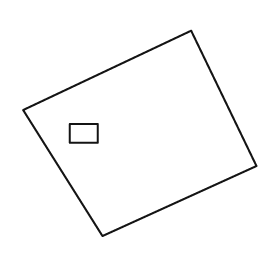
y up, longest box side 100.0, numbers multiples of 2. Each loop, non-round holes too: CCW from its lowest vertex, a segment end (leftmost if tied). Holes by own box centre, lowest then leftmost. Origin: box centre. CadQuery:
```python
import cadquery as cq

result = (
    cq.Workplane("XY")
    .moveTo(-16.0, -44.0)
    .lineTo(50.0, -14.0)
    .lineTo(22.0, 44.0)
    .lineTo(-50.0, 10.0)
    .close()
    .moveTo(-30.0, -4.0)
    .lineTo(-18.0, -4.0)
    .lineTo(-18.0, 4.0)
    .lineTo(-30.0, 4.0)
    .close()
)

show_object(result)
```